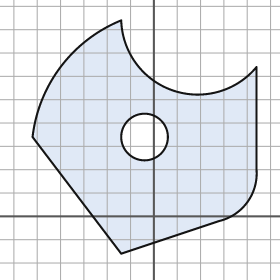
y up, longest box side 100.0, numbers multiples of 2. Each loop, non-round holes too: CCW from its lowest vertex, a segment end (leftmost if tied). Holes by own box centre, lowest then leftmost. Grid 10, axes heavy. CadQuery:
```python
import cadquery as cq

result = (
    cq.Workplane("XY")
    .moveTo(-14.0, -16.0)
    .lineTo(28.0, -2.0)
    .threePointArc((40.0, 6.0), (44.0, 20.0))
    .lineTo(44.0, 64.0)
    .threePointArc((8.0, 54.0), (-14.0, 84.0))
    .threePointArc((-40.0, 64.0), (-52.0, 34.0))
    .close()
    .moveTo(-4.0, 34.0)
    .circle(10.0)
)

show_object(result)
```